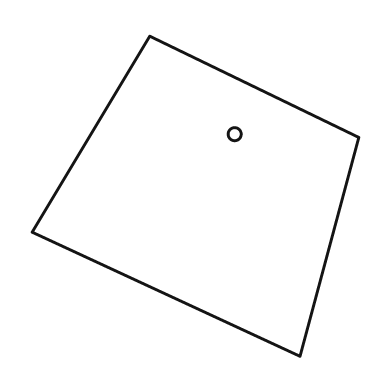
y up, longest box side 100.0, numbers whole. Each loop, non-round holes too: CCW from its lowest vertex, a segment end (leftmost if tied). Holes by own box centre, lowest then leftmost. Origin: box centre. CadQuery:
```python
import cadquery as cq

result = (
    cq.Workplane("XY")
    .moveTo(32.0, -49.0)
    .lineTo(50.0, 18.0)
    .lineTo(-14.0, 49.0)
    .lineTo(-50.0, -11.0)
    .close()
    .moveTo(12.0, 19.0)
    .circle(2.0)
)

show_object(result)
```